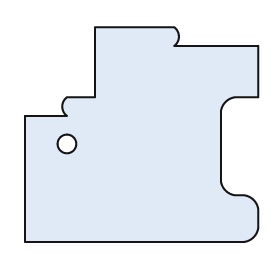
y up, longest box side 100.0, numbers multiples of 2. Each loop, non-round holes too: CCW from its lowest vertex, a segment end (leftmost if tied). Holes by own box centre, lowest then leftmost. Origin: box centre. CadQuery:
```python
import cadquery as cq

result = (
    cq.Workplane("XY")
    .moveTo(-50.0, -46.0)
    .lineTo(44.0, -46.0)
    .threePointArc((48.0, -44.0), (50.0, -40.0))
    .lineTo(50.0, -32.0)
    .threePointArc((48.0, -28.0), (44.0, -26.0))
    .lineTo(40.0, -26.0)
    .threePointArc((36.0, -24.0), (34.0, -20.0))
    .lineTo(34.0, 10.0)
    .threePointArc((36.0, 14.0), (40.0, 16.0))
    .lineTo(50.0, 16.0)
    .lineTo(50.0, 38.0)
    .lineTo(14.0, 38.0)
    .threePointArc((16.0, 42.0), (14.0, 46.0))
    .lineTo(-20.0, 46.0)
    .lineTo(-20.0, 16.0)
    .lineTo(-32.0, 16.0)
    .threePointArc((-34.0, 12.0), (-32.0, 8.0))
    .lineTo(-50.0, 8.0)
    .close()
    .moveTo(-32.0, -4.0)
    .circle(4.0)
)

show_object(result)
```